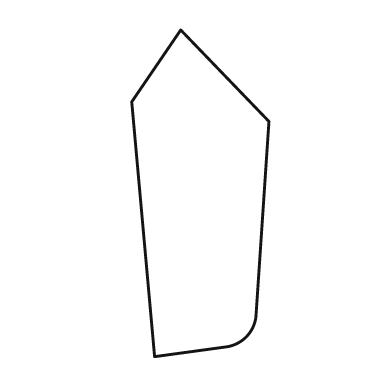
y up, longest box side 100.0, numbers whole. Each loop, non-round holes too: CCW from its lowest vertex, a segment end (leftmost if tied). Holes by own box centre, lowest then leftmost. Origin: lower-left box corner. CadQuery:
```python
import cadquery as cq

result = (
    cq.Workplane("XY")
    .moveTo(7.0, 0.0)
    .lineTo(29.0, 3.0)
    .threePointArc((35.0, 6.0), (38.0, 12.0))
    .lineTo(42.0, 72.0)
    .lineTo(15.0, 100.0)
    .lineTo(0.0, 78.0)
    .close()
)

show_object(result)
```